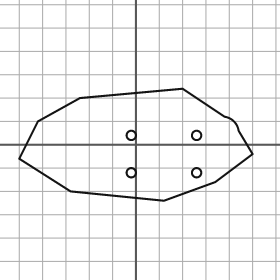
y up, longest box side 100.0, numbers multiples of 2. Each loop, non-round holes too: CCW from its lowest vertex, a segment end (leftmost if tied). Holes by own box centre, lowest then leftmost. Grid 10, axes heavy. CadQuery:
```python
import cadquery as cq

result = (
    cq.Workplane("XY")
    .moveTo(12.0, -24.0)
    .lineTo(34.0, -16.0)
    .lineTo(50.0, -4.0)
    .lineTo(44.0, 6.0)
    .threePointArc((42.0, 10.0), (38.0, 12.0))
    .lineTo(20.0, 24.0)
    .lineTo(-24.0, 20.0)
    .lineTo(-42.0, 10.0)
    .lineTo(-50.0, -6.0)
    .lineTo(-28.0, -20.0)
    .close()
    .moveTo(-2.0, -12.0)
    .circle(2.0)
    .moveTo(26.0, -12.0)
    .circle(2.0)
    .moveTo(-2.0, 4.0)
    .circle(2.0)
    .moveTo(26.0, 4.0)
    .circle(2.0)
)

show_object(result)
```